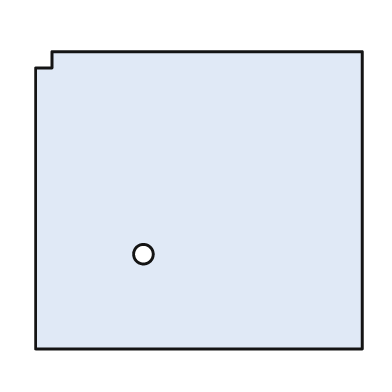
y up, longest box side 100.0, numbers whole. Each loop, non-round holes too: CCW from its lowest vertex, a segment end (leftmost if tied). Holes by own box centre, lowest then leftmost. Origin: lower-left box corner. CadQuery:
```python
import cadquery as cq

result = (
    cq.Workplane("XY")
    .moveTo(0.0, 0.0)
    .lineTo(100.0, 0.0)
    .lineTo(100.0, 91.0)
    .lineTo(5.0, 91.0)
    .lineTo(5.0, 86.0)
    .lineTo(0.0, 86.0)
    .close()
    .moveTo(33.0, 29.0)
    .circle(3.0)
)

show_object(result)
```